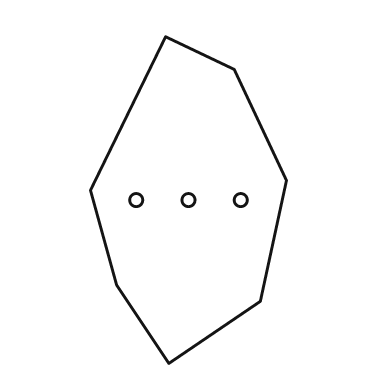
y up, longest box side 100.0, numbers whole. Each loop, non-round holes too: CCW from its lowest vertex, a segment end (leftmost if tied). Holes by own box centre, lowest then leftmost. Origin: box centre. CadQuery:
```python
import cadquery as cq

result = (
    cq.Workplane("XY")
    .moveTo(-6.0, -50.0)
    .lineTo(22.0, -31.0)
    .lineTo(30.0, 6.0)
    .lineTo(14.0, 40.0)
    .lineTo(-7.0, 50.0)
    .lineTo(-30.0, 3.0)
    .lineTo(-22.0, -26.0)
    .close()
    .moveTo(-16.0, 0.0)
    .circle(2.0)
    .moveTo(0.0, 0.0)
    .circle(2.0)
    .moveTo(16.0, 0.0)
    .circle(2.0)
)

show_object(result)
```